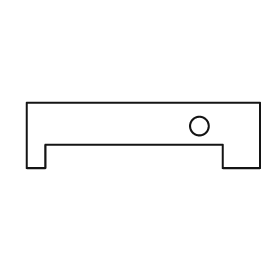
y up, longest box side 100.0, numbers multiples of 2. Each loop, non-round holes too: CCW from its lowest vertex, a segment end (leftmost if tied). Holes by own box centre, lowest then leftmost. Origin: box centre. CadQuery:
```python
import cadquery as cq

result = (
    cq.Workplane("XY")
    .moveTo(-50.0, -14.0)
    .lineTo(-42.0, -14.0)
    .lineTo(-42.0, -4.0)
    .lineTo(34.0, -4.0)
    .lineTo(34.0, -14.0)
    .lineTo(50.0, -14.0)
    .lineTo(50.0, 14.0)
    .lineTo(-50.0, 14.0)
    .close()
    .moveTo(24.0, 4.0)
    .circle(4.0)
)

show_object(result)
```